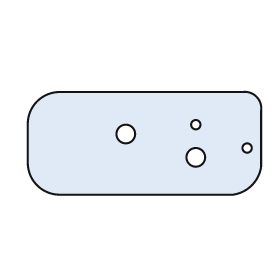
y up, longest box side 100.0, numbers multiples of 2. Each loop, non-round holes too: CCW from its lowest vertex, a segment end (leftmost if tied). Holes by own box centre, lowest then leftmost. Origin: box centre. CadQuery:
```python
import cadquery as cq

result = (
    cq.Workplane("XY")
    .moveTo(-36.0, -22.0)
    .lineTo(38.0, -22.0)
    .threePointArc((46.0, -18.0), (50.0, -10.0))
    .lineTo(50.0, 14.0)
    .threePointArc((48.0, 20.0), (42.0, 22.0))
    .lineTo(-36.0, 22.0)
    .threePointArc((-46.0, 18.0), (-50.0, 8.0))
    .lineTo(-50.0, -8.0)
    .threePointArc((-46.0, -18.0), (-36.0, -22.0))
    .close()
    .moveTo(22.0, -6.0)
    .circle(4.0)
    .moveTo(44.0, -2.0)
    .circle(2.0)
    .moveTo(-8.0, 4.0)
    .circle(4.0)
    .moveTo(22.0, 8.0)
    .circle(2.0)
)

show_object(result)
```